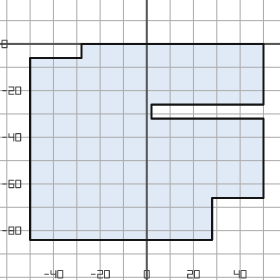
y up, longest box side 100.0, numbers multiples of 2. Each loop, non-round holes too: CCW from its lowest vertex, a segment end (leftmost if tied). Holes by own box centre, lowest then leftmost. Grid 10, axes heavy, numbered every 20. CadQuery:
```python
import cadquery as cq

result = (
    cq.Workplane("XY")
    .moveTo(-50.0, -84.0)
    .lineTo(28.0, -84.0)
    .lineTo(28.0, -66.0)
    .lineTo(50.0, -66.0)
    .lineTo(50.0, -32.0)
    .lineTo(2.0, -32.0)
    .lineTo(2.0, -26.0)
    .lineTo(50.0, -26.0)
    .lineTo(50.0, 0.0)
    .lineTo(-28.0, 0.0)
    .lineTo(-28.0, -6.0)
    .lineTo(-50.0, -6.0)
    .close()
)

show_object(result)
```